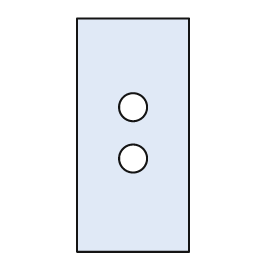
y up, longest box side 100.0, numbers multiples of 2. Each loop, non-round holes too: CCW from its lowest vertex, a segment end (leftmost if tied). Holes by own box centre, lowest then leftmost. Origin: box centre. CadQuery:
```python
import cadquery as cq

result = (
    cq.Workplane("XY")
    .moveTo(-24.0, -50.0)
    .lineTo(24.0, -50.0)
    .lineTo(24.0, 50.0)
    .lineTo(-24.0, 50.0)
    .close()
    .moveTo(0.0, -10.0)
    .circle(6.0)
    .moveTo(0.0, 12.0)
    .circle(6.0)
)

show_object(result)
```